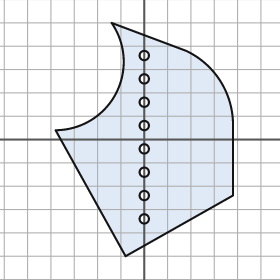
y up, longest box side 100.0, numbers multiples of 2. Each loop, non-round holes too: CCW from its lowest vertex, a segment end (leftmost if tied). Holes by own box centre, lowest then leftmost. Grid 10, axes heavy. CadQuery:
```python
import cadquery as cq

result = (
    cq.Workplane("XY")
    .moveTo(-8.0, -50.0)
    .lineTo(38.0, -24.0)
    .lineTo(38.0, 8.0)
    .threePointArc((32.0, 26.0), (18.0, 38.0))
    .lineTo(-14.0, 50.0)
    .threePointArc((-12.0, 20.0), (-38.0, 4.0))
    .close()
    .moveTo(0.0, -34.0)
    .circle(2.0)
    .moveTo(0.0, -24.0)
    .circle(2.0)
    .moveTo(0.0, -14.0)
    .circle(2.0)
    .moveTo(0.0, -4.0)
    .circle(2.0)
    .moveTo(0.0, 6.0)
    .circle(2.0)
    .moveTo(0.0, 16.0)
    .circle(2.0)
    .moveTo(0.0, 26.0)
    .circle(2.0)
    .moveTo(0.0, 36.0)
    .circle(2.0)
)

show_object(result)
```